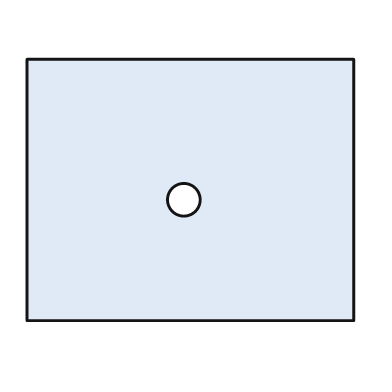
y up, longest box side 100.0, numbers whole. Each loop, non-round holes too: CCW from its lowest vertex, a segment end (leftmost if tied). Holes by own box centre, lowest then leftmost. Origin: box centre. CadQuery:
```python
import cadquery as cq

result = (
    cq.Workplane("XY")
    .moveTo(-50.0, -40.0)
    .lineTo(50.0, -40.0)
    .lineTo(50.0, 40.0)
    .lineTo(-50.0, 40.0)
    .close()
    .moveTo(-2.0, -3.0)
    .circle(5.0)
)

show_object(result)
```